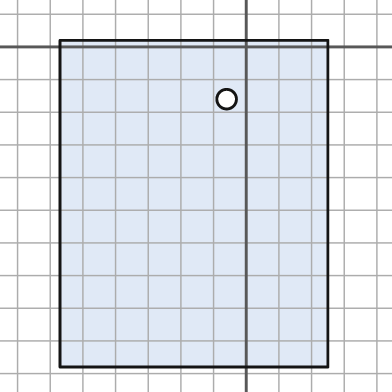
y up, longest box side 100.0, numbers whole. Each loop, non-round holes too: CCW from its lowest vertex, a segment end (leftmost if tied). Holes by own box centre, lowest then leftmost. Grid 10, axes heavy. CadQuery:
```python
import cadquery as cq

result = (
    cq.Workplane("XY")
    .moveTo(-57.0, -98.0)
    .lineTo(25.0, -98.0)
    .lineTo(25.0, 2.0)
    .lineTo(-57.0, 2.0)
    .close()
    .moveTo(-6.0, -16.0)
    .circle(3.0)
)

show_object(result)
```